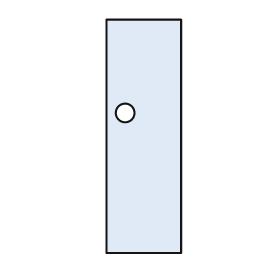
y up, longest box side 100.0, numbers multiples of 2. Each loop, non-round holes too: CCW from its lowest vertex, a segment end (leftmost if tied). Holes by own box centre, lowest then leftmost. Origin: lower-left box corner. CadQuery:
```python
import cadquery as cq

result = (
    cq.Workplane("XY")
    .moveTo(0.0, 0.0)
    .lineTo(32.0, 0.0)
    .lineTo(32.0, 100.0)
    .lineTo(0.0, 100.0)
    .close()
    .moveTo(8.0, 60.0)
    .circle(4.0)
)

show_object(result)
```